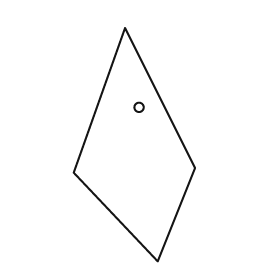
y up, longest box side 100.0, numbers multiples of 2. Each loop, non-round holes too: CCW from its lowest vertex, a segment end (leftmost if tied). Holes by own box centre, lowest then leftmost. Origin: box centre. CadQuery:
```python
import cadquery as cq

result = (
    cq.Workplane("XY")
    .moveTo(10.0, -50.0)
    .lineTo(26.0, -10.0)
    .lineTo(-4.0, 50.0)
    .lineTo(-26.0, -12.0)
    .close()
    .moveTo(2.0, 16.0)
    .circle(2.0)
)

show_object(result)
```